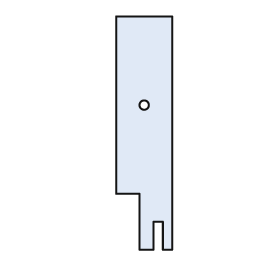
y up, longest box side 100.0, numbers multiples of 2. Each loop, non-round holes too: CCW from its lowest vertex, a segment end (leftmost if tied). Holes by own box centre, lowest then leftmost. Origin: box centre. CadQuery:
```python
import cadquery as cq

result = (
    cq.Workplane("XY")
    .moveTo(-2.0, -50.0)
    .lineTo(4.0, -50.0)
    .lineTo(4.0, -38.0)
    .lineTo(8.0, -38.0)
    .lineTo(8.0, -50.0)
    .lineTo(12.0, -50.0)
    .lineTo(12.0, 50.0)
    .lineTo(-12.0, 50.0)
    .lineTo(-12.0, -26.0)
    .lineTo(-2.0, -26.0)
    .close()
    .moveTo(0.0, 12.0)
    .circle(2.0)
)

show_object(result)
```